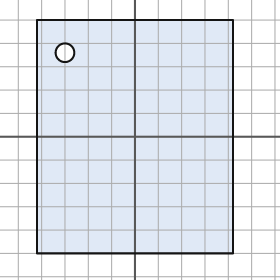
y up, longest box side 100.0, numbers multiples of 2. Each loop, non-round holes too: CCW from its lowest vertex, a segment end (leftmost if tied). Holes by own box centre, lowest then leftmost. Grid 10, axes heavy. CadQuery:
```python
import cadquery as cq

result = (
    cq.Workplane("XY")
    .moveTo(-42.0, -50.0)
    .lineTo(42.0, -50.0)
    .lineTo(42.0, 50.0)
    .lineTo(-42.0, 50.0)
    .close()
    .moveTo(-30.0, 36.0)
    .circle(4.0)
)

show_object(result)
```